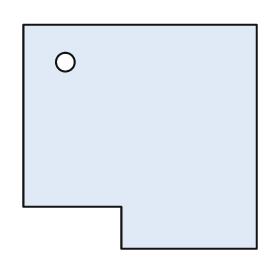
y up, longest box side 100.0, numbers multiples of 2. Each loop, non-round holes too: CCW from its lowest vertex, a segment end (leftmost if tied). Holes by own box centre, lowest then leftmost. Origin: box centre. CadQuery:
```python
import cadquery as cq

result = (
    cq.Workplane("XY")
    .moveTo(-8.0, -48.0)
    .lineTo(50.0, -48.0)
    .lineTo(50.0, 48.0)
    .lineTo(-50.0, 48.0)
    .lineTo(-50.0, -30.0)
    .lineTo(-8.0, -30.0)
    .close()
    .moveTo(-32.0, 32.0)
    .circle(4.0)
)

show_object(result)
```